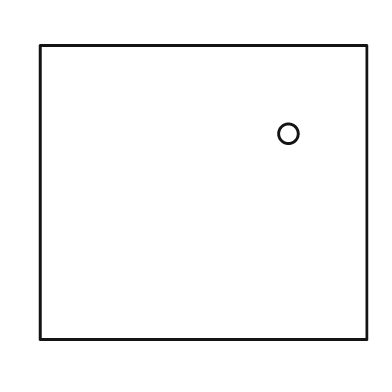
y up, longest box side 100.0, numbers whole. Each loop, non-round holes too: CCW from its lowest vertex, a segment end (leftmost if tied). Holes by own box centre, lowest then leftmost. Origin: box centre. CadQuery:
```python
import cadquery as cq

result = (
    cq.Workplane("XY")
    .moveTo(-50.0, -45.0)
    .lineTo(50.0, -45.0)
    .lineTo(50.0, 45.0)
    .lineTo(-50.0, 45.0)
    .close()
    .moveTo(26.0, 18.0)
    .circle(3.0)
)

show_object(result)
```